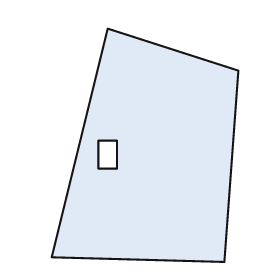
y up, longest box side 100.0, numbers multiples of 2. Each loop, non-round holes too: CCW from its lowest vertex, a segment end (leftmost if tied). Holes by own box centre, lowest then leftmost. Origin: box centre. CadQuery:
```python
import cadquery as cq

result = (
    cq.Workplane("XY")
    .moveTo(34.0, -50.0)
    .lineTo(40.0, 32.0)
    .lineTo(-16.0, 50.0)
    .lineTo(-40.0, -48.0)
    .close()
    .moveTo(-20.0, -10.0)
    .lineTo(-12.0, -10.0)
    .lineTo(-12.0, 2.0)
    .lineTo(-20.0, 2.0)
    .close()
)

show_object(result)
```